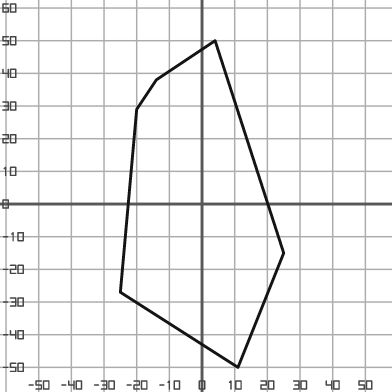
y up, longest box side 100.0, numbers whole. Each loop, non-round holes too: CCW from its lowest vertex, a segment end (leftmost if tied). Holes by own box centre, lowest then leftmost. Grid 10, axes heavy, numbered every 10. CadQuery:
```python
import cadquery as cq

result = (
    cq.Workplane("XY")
    .moveTo(11.0, -50.0)
    .lineTo(25.0, -15.0)
    .lineTo(4.0, 50.0)
    .lineTo(-14.0, 38.0)
    .lineTo(-20.0, 29.0)
    .lineTo(-25.0, -27.0)
    .close()
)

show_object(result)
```